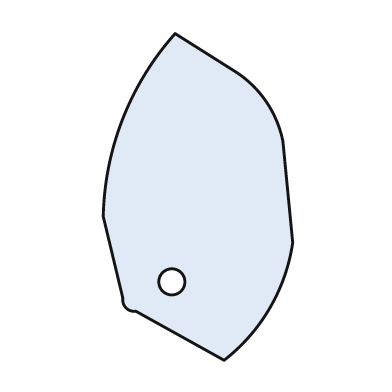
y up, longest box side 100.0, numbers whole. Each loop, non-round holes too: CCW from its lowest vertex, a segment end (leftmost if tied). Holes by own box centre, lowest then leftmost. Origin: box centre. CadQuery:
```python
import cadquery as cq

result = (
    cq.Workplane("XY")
    .moveTo(8.0, -50.0)
    .threePointArc((22.0, -34.0), (29.0, -14.0))
    .lineTo(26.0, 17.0)
    .threePointArc((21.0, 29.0), (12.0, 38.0))
    .lineTo(-7.0, 50.0)
    .threePointArc((-23.0, 24.0), (-29.0, -6.0))
    .lineTo(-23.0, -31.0)
    .threePointArc((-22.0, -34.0), (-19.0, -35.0))
    .close()
    .moveTo(-8.0, -26.0)
    .circle(4.0)
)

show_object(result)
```